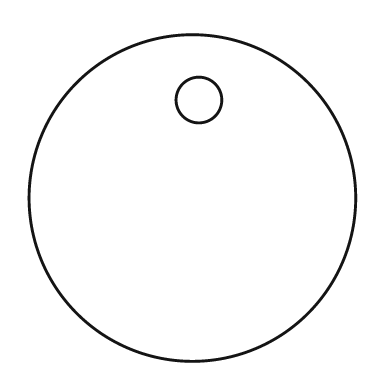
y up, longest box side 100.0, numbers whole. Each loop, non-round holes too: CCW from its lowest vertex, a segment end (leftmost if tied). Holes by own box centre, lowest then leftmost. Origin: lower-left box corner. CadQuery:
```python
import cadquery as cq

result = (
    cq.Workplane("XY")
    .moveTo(50.0, 50.0)
    .circle(50.0)
    .moveTo(52.0, 80.0)
    .circle(7.0)
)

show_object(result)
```